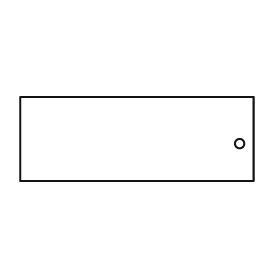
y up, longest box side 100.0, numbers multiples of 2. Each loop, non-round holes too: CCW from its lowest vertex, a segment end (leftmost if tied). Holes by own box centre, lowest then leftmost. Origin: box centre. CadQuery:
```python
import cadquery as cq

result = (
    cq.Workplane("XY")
    .moveTo(-50.0, -18.0)
    .lineTo(50.0, -18.0)
    .lineTo(50.0, 18.0)
    .lineTo(-50.0, 18.0)
    .close()
    .moveTo(44.0, -2.0)
    .circle(2.0)
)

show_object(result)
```